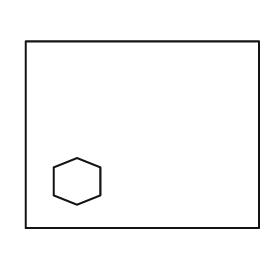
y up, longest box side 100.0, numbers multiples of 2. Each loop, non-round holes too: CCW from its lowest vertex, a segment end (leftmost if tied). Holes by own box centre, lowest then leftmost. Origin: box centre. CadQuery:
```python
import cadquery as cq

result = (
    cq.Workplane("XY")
    .moveTo(-50.0, -40.0)
    .lineTo(50.0, -40.0)
    .lineTo(50.0, 40.0)
    .lineTo(-50.0, 40.0)
    .close()
    .moveTo(-28.0, -30.0)
    .lineTo(-18.0, -26.0)
    .lineTo(-18.0, -14.0)
    .lineTo(-28.0, -10.0)
    .lineTo(-38.0, -14.0)
    .lineTo(-38.0, -26.0)
    .close()
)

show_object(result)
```